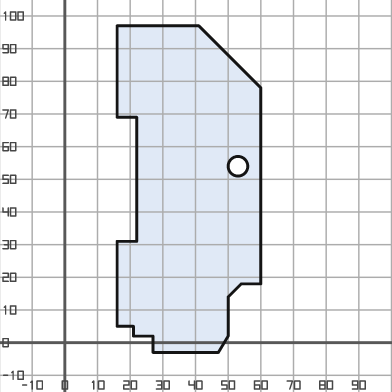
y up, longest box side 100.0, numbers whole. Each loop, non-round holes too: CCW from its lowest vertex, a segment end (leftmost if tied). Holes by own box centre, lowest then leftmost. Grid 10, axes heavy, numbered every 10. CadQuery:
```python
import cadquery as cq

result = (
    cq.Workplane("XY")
    .moveTo(27.0, -3.0)
    .lineTo(47.0, -3.0)
    .lineTo(50.0, 2.0)
    .lineTo(50.0, 14.0)
    .lineTo(54.0, 18.0)
    .lineTo(60.0, 18.0)
    .lineTo(60.0, 78.0)
    .lineTo(41.0, 97.0)
    .lineTo(16.0, 97.0)
    .lineTo(16.0, 69.0)
    .lineTo(22.0, 69.0)
    .lineTo(22.0, 31.0)
    .lineTo(16.0, 31.0)
    .lineTo(16.0, 5.0)
    .lineTo(21.0, 5.0)
    .lineTo(21.0, 2.0)
    .lineTo(27.0, 2.0)
    .close()
    .moveTo(53.0, 54.0)
    .circle(3.0)
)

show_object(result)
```